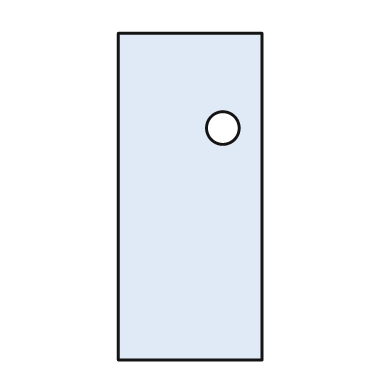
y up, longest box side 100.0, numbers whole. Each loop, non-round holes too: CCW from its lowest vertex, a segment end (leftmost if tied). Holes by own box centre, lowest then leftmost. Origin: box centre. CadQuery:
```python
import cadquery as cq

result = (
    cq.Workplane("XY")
    .moveTo(-22.0, -50.0)
    .lineTo(22.0, -50.0)
    .lineTo(22.0, 50.0)
    .lineTo(-22.0, 50.0)
    .close()
    .moveTo(10.0, 21.0)
    .circle(5.0)
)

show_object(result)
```